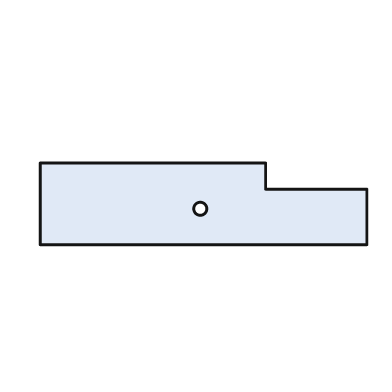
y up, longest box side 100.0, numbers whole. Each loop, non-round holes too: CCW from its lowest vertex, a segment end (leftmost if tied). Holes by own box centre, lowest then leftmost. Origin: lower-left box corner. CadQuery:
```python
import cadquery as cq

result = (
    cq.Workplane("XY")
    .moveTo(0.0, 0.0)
    .lineTo(100.0, 0.0)
    .lineTo(100.0, 17.0)
    .lineTo(69.0, 17.0)
    .lineTo(69.0, 25.0)
    .lineTo(0.0, 25.0)
    .close()
    .moveTo(49.0, 11.0)
    .circle(2.0)
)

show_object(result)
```